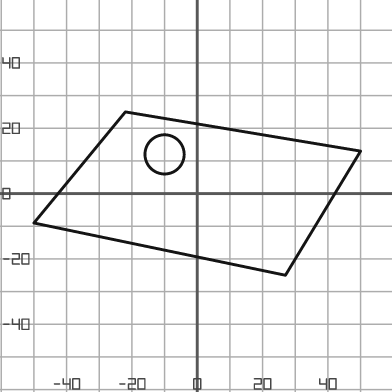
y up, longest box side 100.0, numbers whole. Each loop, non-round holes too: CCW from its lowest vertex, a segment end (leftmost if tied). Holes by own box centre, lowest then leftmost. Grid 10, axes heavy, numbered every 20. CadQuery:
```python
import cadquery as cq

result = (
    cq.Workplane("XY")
    .moveTo(27.0, -25.0)
    .lineTo(50.0, 13.0)
    .lineTo(-22.0, 25.0)
    .lineTo(-50.0, -9.0)
    .close()
    .moveTo(-10.0, 12.0)
    .circle(6.0)
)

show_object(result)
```